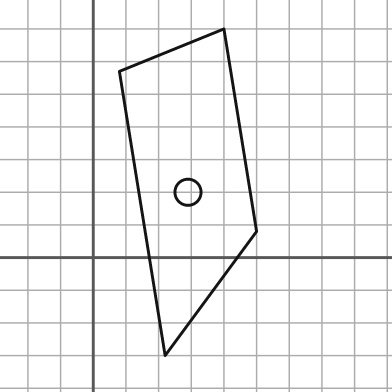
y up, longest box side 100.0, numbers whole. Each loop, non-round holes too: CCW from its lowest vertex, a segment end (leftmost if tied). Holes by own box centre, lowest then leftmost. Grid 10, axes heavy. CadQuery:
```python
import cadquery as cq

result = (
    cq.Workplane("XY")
    .moveTo(22.0, -30.0)
    .lineTo(50.0, 8.0)
    .lineTo(40.0, 70.0)
    .lineTo(8.0, 57.0)
    .close()
    .moveTo(29.0, 20.0)
    .circle(4.0)
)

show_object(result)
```